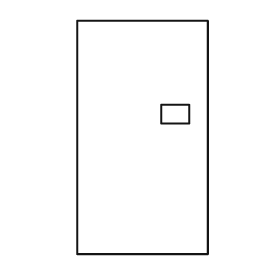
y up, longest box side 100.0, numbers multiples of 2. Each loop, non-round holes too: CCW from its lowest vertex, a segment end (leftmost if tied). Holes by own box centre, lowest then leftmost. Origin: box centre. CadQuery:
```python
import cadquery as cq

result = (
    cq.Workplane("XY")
    .moveTo(-28.0, -50.0)
    .lineTo(28.0, -50.0)
    .lineTo(28.0, 50.0)
    .lineTo(-28.0, 50.0)
    .close()
    .moveTo(8.0, 6.0)
    .lineTo(20.0, 6.0)
    .lineTo(20.0, 14.0)
    .lineTo(8.0, 14.0)
    .close()
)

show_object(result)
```